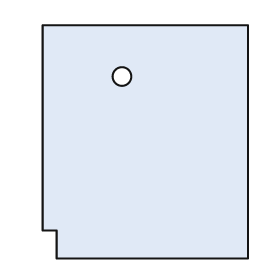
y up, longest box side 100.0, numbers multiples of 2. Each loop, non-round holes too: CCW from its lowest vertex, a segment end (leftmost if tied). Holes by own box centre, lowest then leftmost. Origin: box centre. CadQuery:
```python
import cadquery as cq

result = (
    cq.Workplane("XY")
    .moveTo(-38.0, -50.0)
    .lineTo(44.0, -50.0)
    .lineTo(44.0, 50.0)
    .lineTo(-44.0, 50.0)
    .lineTo(-44.0, -38.0)
    .lineTo(-38.0, -38.0)
    .close()
    .moveTo(-10.0, 28.0)
    .circle(4.0)
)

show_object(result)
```